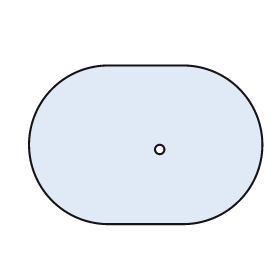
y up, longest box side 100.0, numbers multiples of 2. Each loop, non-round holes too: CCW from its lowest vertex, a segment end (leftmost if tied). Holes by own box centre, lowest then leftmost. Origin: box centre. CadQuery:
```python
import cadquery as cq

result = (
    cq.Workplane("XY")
    .moveTo(-16.0, -34.0)
    .lineTo(16.0, -34.0)
    .threePointArc((50.0, 0.0), (16.0, 34.0))
    .lineTo(-16.0, 34.0)
    .threePointArc((-50.0, 0.0), (-16.0, -34.0))
    .close()
    .moveTo(6.0, -2.0)
    .circle(2.0)
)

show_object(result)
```